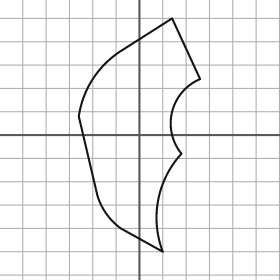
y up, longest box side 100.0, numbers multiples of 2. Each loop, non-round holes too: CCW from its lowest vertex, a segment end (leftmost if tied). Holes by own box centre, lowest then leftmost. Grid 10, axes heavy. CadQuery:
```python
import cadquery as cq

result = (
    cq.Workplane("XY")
    .moveTo(10.0, -50.0)
    .threePointArc((8.0, -28.0), (18.0, -8.0))
    .threePointArc((14.0, 10.0), (26.0, 24.0))
    .lineTo(14.0, 50.0)
    .lineTo(-8.0, 36.0)
    .threePointArc((-20.0, 24.0), (-26.0, 8.0))
    .lineTo(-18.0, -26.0)
    .threePointArc((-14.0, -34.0), (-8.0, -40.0))
    .close()
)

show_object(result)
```